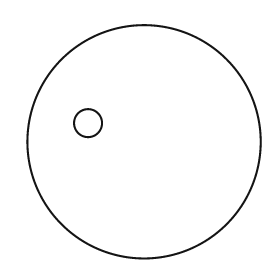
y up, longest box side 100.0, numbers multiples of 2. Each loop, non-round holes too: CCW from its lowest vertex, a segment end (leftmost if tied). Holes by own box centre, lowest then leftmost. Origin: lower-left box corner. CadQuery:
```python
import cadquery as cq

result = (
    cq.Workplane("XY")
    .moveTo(50.0, 50.0)
    .circle(50.0)
    .moveTo(26.0, 58.0)
    .circle(6.0)
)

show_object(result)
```